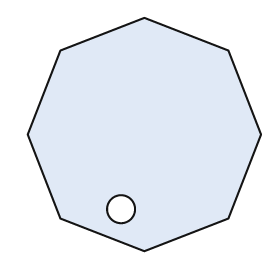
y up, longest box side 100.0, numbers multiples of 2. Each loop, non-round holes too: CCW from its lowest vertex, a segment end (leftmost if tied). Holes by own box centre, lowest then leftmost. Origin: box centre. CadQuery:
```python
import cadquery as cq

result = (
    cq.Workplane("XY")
    .moveTo(0.0, -50.0)
    .lineTo(36.0, -36.0)
    .lineTo(50.0, 0.0)
    .lineTo(36.0, 36.0)
    .lineTo(0.0, 50.0)
    .lineTo(-36.0, 36.0)
    .lineTo(-50.0, 0.0)
    .lineTo(-36.0, -36.0)
    .close()
    .moveTo(-10.0, -32.0)
    .circle(6.0)
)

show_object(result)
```